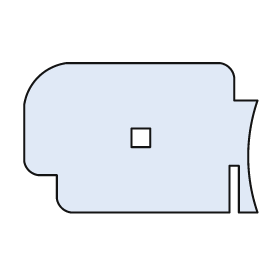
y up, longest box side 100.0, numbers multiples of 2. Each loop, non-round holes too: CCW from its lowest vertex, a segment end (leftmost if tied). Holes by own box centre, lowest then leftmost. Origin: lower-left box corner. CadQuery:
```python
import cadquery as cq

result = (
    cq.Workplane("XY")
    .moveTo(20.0, 0.0)
    .lineTo(88.0, 0.0)
    .lineTo(88.0, 20.0)
    .lineTo(92.0, 20.0)
    .lineTo(92.0, 0.0)
    .lineTo(100.0, 0.0)
    .threePointArc((96.0, 24.0), (100.0, 48.0))
    .lineTo(90.0, 48.0)
    .lineTo(90.0, 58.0)
    .threePointArc((88.0, 62.0), (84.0, 64.0))
    .lineTo(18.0, 64.0)
    .threePointArc((6.0, 58.0), (0.0, 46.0))
    .lineTo(0.0, 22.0)
    .threePointArc((2.0, 18.0), (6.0, 16.0))
    .lineTo(14.0, 16.0)
    .lineTo(14.0, 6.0)
    .threePointArc((16.0, 2.0), (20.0, 0.0))
    .close()
    .moveTo(46.0, 28.0)
    .lineTo(54.0, 28.0)
    .lineTo(54.0, 36.0)
    .lineTo(46.0, 36.0)
    .close()
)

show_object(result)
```